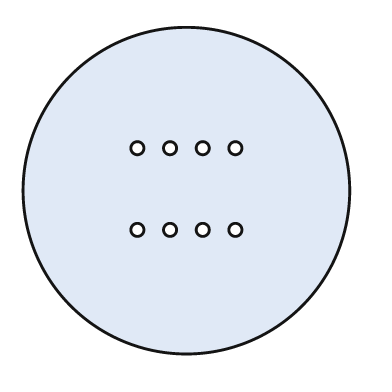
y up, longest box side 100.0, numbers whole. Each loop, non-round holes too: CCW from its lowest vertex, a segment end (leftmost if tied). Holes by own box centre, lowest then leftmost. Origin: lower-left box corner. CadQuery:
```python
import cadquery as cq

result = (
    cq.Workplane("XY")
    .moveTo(50.0, 50.0)
    .circle(50.0)
    .moveTo(35.0, 38.0)
    .circle(2.0)
    .moveTo(45.0, 38.0)
    .circle(2.0)
    .moveTo(55.0, 38.0)
    .circle(2.0)
    .moveTo(65.0, 38.0)
    .circle(2.0)
    .moveTo(35.0, 63.0)
    .circle(2.0)
    .moveTo(45.0, 63.0)
    .circle(2.0)
    .moveTo(55.0, 63.0)
    .circle(2.0)
    .moveTo(65.0, 63.0)
    .circle(2.0)
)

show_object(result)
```